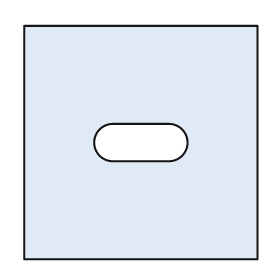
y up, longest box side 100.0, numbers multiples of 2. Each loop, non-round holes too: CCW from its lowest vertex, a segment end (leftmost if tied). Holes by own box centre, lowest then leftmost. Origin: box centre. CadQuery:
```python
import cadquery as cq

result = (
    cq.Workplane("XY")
    .moveTo(-50.0, -50.0)
    .lineTo(50.0, -50.0)
    .lineTo(50.0, 50.0)
    .lineTo(-50.0, 50.0)
    .close()
    .moveTo(-12.0, -8.0)
    .lineTo(12.0, -8.0)
    .threePointArc((20.0, 0.0), (12.0, 8.0))
    .lineTo(-12.0, 8.0)
    .threePointArc((-20.0, 0.0), (-12.0, -8.0))
    .close()
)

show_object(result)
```